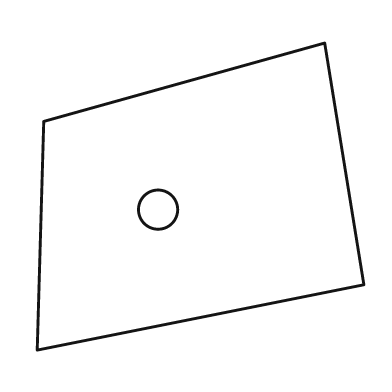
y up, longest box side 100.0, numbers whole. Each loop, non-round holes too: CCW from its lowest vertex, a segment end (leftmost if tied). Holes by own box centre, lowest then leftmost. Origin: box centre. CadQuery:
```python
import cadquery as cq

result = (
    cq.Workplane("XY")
    .moveTo(-50.0, -47.0)
    .lineTo(50.0, -27.0)
    .lineTo(38.0, 47.0)
    .lineTo(-48.0, 23.0)
    .close()
    .moveTo(-13.0, -4.0)
    .circle(6.0)
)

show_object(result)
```